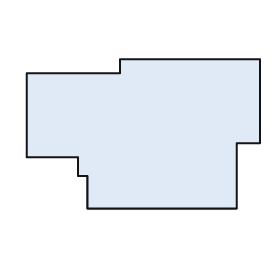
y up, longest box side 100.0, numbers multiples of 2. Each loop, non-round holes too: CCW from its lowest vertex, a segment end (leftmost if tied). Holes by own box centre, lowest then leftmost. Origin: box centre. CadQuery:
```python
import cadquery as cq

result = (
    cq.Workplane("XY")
    .moveTo(-24.0, -32.0)
    .lineTo(40.0, -32.0)
    .lineTo(40.0, -4.0)
    .lineTo(50.0, -4.0)
    .lineTo(50.0, 32.0)
    .lineTo(-10.0, 32.0)
    .lineTo(-10.0, 26.0)
    .lineTo(-50.0, 26.0)
    .lineTo(-50.0, -10.0)
    .lineTo(-28.0, -10.0)
    .lineTo(-28.0, -18.0)
    .lineTo(-24.0, -18.0)
    .close()
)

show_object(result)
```